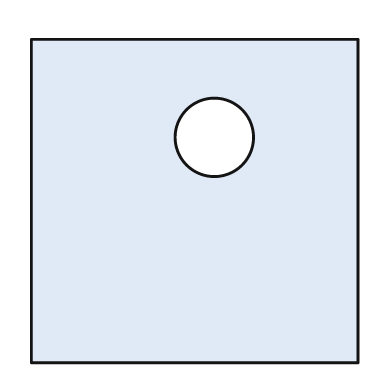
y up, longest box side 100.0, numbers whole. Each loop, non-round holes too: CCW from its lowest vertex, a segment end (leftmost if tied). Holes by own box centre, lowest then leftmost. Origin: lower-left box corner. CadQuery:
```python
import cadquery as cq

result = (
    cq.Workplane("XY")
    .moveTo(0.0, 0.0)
    .lineTo(100.0, 0.0)
    .lineTo(100.0, 99.0)
    .lineTo(0.0, 99.0)
    .close()
    .moveTo(56.0, 69.0)
    .circle(12.0)
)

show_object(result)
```